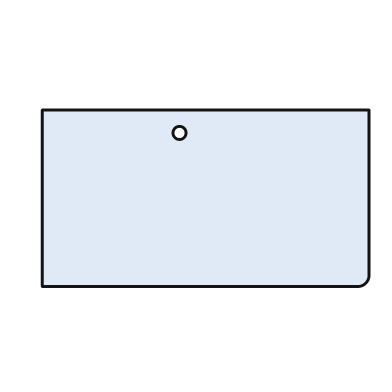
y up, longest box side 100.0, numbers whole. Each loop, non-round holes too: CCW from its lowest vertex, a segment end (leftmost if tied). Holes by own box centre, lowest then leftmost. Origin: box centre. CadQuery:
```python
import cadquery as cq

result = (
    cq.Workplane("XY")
    .moveTo(-50.0, -27.0)
    .lineTo(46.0, -27.0)
    .threePointArc((49.0, -26.0), (50.0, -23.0))
    .lineTo(50.0, 27.0)
    .lineTo(-50.0, 27.0)
    .close()
    .moveTo(-8.0, 20.0)
    .circle(2.0)
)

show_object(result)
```